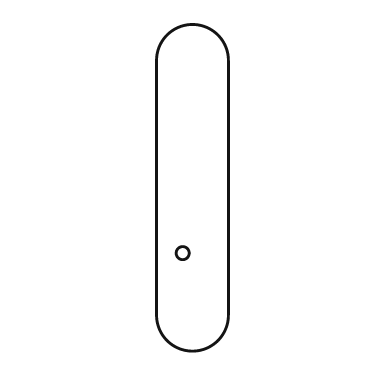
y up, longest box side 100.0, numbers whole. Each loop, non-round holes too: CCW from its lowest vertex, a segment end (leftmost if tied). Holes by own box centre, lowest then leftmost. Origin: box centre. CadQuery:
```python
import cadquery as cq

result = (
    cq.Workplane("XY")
    .moveTo(-11.0, -39.0)
    .threePointArc((0.0, -50.0), (11.0, -39.0))
    .lineTo(11.0, 39.0)
    .threePointArc((0.0, 50.0), (-11.0, 39.0))
    .close()
    .moveTo(-3.0, -20.0)
    .circle(2.0)
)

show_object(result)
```